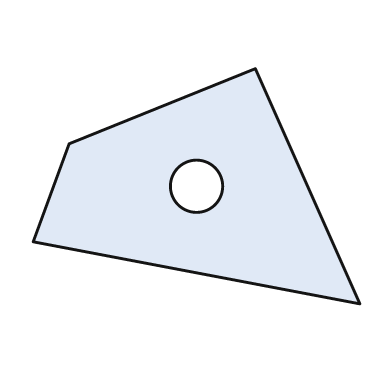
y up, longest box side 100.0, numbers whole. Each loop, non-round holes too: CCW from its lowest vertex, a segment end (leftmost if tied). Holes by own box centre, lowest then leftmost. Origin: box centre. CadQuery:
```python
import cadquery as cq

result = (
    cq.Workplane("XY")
    .moveTo(50.0, -36.0)
    .lineTo(18.0, 36.0)
    .lineTo(-39.0, 13.0)
    .lineTo(-50.0, -17.0)
    .close()
    .moveTo(0.0, 0.0)
    .circle(8.0)
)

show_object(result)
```